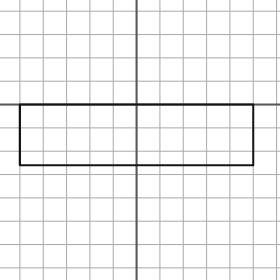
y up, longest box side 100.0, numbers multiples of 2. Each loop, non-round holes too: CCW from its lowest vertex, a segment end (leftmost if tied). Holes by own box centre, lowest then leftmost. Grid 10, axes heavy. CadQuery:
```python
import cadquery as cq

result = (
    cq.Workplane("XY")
    .moveTo(-50.0, -26.0)
    .lineTo(50.0, -26.0)
    .lineTo(50.0, 0.0)
    .lineTo(-50.0, 0.0)
    .close()
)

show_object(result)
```